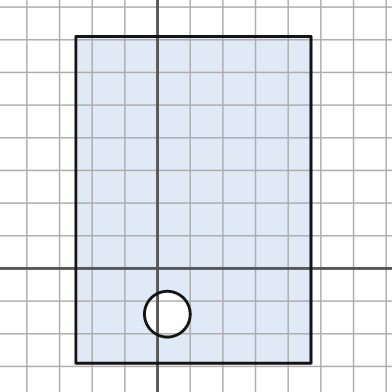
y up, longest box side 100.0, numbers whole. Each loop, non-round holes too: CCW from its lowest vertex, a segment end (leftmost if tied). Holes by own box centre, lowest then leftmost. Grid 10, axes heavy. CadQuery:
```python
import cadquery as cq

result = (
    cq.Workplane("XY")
    .moveTo(-25.0, -29.0)
    .lineTo(47.0, -29.0)
    .lineTo(47.0, 71.0)
    .lineTo(-25.0, 71.0)
    .close()
    .moveTo(3.0, -14.0)
    .circle(7.0)
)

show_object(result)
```